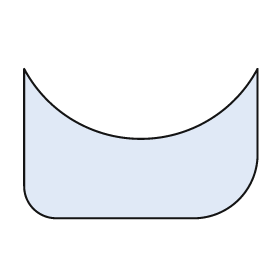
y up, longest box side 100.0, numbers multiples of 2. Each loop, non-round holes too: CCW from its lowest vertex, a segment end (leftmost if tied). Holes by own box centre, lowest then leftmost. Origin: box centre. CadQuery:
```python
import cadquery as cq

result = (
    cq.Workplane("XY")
    .moveTo(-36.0, -32.0)
    .lineTo(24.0, -32.0)
    .threePointArc((42.0, -24.0), (50.0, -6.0))
    .lineTo(50.0, 32.0)
    .threePointArc((0.0, 2.0), (-50.0, 32.0))
    .lineTo(-50.0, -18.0)
    .threePointArc((-46.0, -28.0), (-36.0, -32.0))
    .close()
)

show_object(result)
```